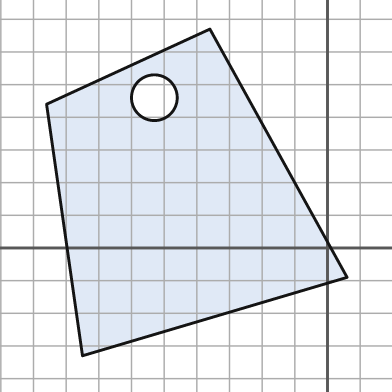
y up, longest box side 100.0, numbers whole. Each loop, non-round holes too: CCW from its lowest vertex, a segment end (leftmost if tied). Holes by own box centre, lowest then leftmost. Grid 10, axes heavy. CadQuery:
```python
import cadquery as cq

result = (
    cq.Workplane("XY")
    .moveTo(-75.0, -33.0)
    .lineTo(6.0, -9.0)
    .lineTo(-36.0, 67.0)
    .lineTo(-86.0, 44.0)
    .close()
    .moveTo(-53.0, 46.0)
    .circle(7.0)
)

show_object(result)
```